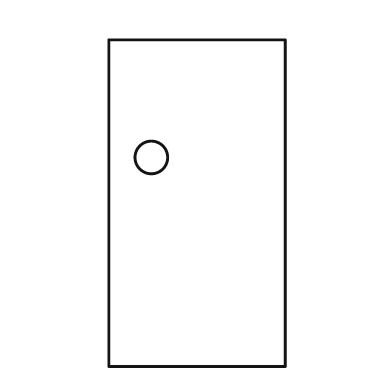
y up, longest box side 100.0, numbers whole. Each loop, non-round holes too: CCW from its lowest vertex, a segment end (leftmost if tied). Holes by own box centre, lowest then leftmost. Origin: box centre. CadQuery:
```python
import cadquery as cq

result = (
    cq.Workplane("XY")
    .moveTo(-27.0, -50.0)
    .lineTo(27.0, -50.0)
    .lineTo(27.0, 50.0)
    .lineTo(-27.0, 50.0)
    .close()
    .moveTo(-14.0, 14.0)
    .circle(5.0)
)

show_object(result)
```